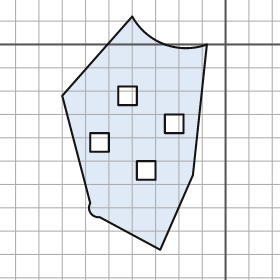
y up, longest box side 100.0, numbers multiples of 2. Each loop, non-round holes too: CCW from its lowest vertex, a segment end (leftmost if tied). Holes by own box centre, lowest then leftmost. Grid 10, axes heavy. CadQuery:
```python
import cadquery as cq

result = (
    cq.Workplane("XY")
    .moveTo(-28.0, -88.0)
    .lineTo(-14.0, -56.0)
    .lineTo(-8.0, 0.0)
    .threePointArc((-26.0, 0.0), (-40.0, 12.0))
    .lineTo(-70.0, -22.0)
    .lineTo(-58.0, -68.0)
    .threePointArc((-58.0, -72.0), (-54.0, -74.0))
    .close()
    .moveTo(-38.0, -58.0)
    .lineTo(-30.0, -58.0)
    .lineTo(-30.0, -50.0)
    .lineTo(-38.0, -50.0)
    .close()
    .moveTo(-58.0, -46.0)
    .lineTo(-50.0, -46.0)
    .lineTo(-50.0, -38.0)
    .lineTo(-58.0, -38.0)
    .close()
    .moveTo(-26.0, -38.0)
    .lineTo(-18.0, -38.0)
    .lineTo(-18.0, -30.0)
    .lineTo(-26.0, -30.0)
    .close()
    .moveTo(-46.0, -26.0)
    .lineTo(-38.0, -26.0)
    .lineTo(-38.0, -18.0)
    .lineTo(-46.0, -18.0)
    .close()
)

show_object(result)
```